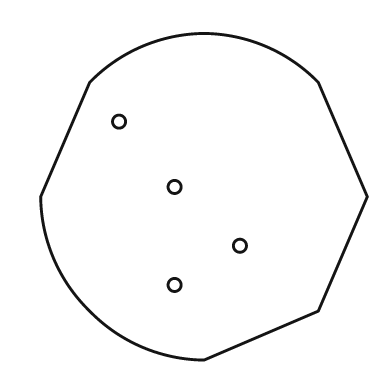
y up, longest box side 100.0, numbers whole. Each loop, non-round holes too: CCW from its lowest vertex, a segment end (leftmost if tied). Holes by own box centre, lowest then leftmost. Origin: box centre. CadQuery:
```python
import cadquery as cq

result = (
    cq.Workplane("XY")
    .moveTo(0.0, -50.0)
    .lineTo(35.0, -35.0)
    .lineTo(50.0, 0.0)
    .lineTo(35.0, 35.0)
    .threePointArc((19.0, 46.0), (0.0, 50.0))
    .threePointArc((-19.0, 46.0), (-35.0, 35.0))
    .lineTo(-50.0, 0.0)
    .threePointArc((-46.0, -19.0), (-35.0, -35.0))
    .threePointArc((-19.0, -46.0), (0.0, -50.0))
    .close()
    .moveTo(-9.0, -27.0)
    .circle(2.0)
    .moveTo(11.0, -15.0)
    .circle(2.0)
    .moveTo(-9.0, 3.0)
    .circle(2.0)
    .moveTo(-26.0, 23.0)
    .circle(2.0)
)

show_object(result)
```